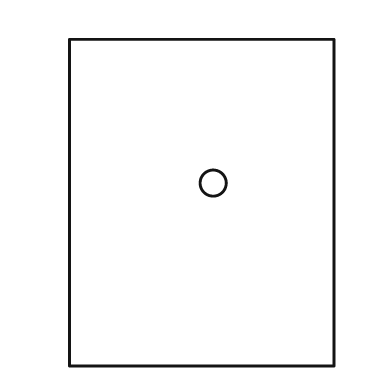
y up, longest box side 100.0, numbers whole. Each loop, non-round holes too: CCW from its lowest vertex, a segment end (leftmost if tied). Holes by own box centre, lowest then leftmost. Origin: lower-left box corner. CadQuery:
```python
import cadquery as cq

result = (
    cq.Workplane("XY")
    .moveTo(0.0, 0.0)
    .lineTo(81.0, 0.0)
    .lineTo(81.0, 100.0)
    .lineTo(0.0, 100.0)
    .close()
    .moveTo(44.0, 56.0)
    .circle(4.0)
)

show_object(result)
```